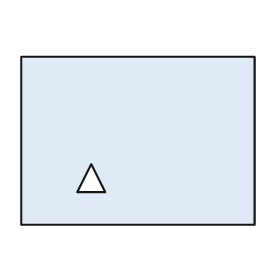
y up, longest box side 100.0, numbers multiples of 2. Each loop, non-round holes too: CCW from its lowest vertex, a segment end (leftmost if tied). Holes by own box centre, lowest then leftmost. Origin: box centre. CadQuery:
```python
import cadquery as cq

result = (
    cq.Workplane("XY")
    .moveTo(-50.0, -36.0)
    .lineTo(50.0, -36.0)
    .lineTo(50.0, 36.0)
    .lineTo(-50.0, 36.0)
    .close()
    .moveTo(-26.0, -22.0)
    .lineTo(-14.0, -22.0)
    .lineTo(-20.0, -10.0)
    .close()
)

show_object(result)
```